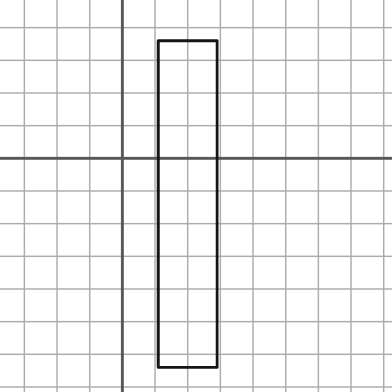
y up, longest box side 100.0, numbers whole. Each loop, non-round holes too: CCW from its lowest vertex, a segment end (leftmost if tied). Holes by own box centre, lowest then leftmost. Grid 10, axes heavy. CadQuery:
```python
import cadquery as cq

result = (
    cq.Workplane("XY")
    .moveTo(11.0, -64.0)
    .lineTo(29.0, -64.0)
    .lineTo(29.0, 36.0)
    .lineTo(11.0, 36.0)
    .close()
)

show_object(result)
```